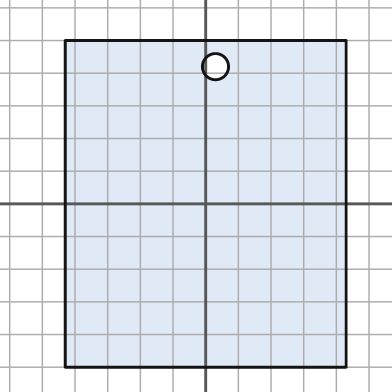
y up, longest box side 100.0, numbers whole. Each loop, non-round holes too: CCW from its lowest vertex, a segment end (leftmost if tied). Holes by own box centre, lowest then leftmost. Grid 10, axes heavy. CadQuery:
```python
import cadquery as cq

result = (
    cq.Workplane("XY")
    .moveTo(-43.0, -50.0)
    .lineTo(43.0, -50.0)
    .lineTo(43.0, 50.0)
    .lineTo(-43.0, 50.0)
    .close()
    .moveTo(3.0, 42.0)
    .circle(4.0)
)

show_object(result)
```